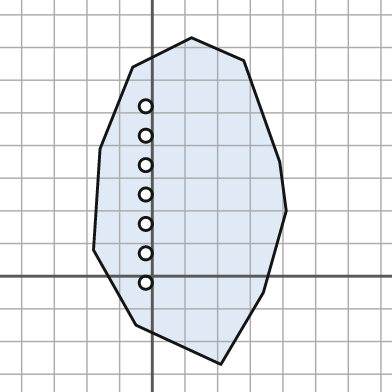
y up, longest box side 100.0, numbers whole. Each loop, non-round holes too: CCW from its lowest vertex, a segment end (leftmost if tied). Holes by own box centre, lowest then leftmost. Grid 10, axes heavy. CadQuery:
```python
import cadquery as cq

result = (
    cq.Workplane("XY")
    .moveTo(21.0, -27.0)
    .lineTo(34.0, -5.0)
    .lineTo(41.0, 20.0)
    .lineTo(39.0, 35.0)
    .lineTo(28.0, 66.0)
    .lineTo(12.0, 73.0)
    .lineTo(-6.0, 64.0)
    .lineTo(-16.0, 39.0)
    .lineTo(-18.0, 8.0)
    .lineTo(-5.0, -15.0)
    .close()
    .moveTo(-2.0, -2.0)
    .circle(2.0)
    .moveTo(-2.0, 7.0)
    .circle(2.0)
    .moveTo(-2.0, 16.0)
    .circle(2.0)
    .moveTo(-2.0, 25.0)
    .circle(2.0)
    .moveTo(-2.0, 34.0)
    .circle(2.0)
    .moveTo(-2.0, 43.0)
    .circle(2.0)
    .moveTo(-2.0, 52.0)
    .circle(2.0)
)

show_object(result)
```